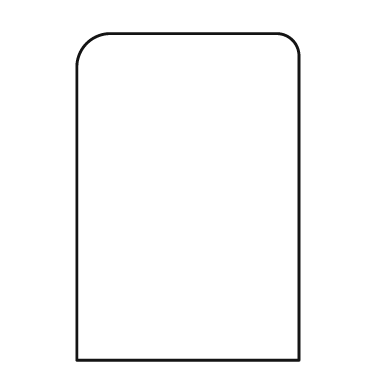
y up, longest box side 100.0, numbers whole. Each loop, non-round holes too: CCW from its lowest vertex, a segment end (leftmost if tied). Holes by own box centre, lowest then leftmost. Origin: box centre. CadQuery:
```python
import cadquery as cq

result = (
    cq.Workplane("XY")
    .moveTo(-34.0, -50.0)
    .lineTo(34.0, -50.0)
    .lineTo(34.0, 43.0)
    .threePointArc((32.0, 48.0), (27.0, 50.0))
    .lineTo(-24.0, 50.0)
    .threePointArc((-31.0, 47.0), (-34.0, 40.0))
    .close()
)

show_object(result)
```